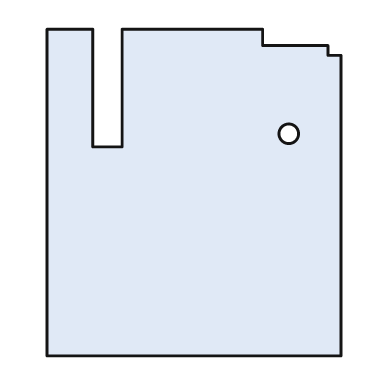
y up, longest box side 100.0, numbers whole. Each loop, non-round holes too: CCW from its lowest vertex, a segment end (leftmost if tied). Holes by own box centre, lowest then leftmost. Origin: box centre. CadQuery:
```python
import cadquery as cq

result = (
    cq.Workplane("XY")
    .moveTo(-45.0, -50.0)
    .lineTo(45.0, -50.0)
    .lineTo(45.0, 42.0)
    .lineTo(41.0, 42.0)
    .lineTo(41.0, 45.0)
    .lineTo(21.0, 45.0)
    .lineTo(21.0, 50.0)
    .lineTo(-22.0, 50.0)
    .lineTo(-22.0, 14.0)
    .lineTo(-31.0, 14.0)
    .lineTo(-31.0, 50.0)
    .lineTo(-45.0, 50.0)
    .close()
    .moveTo(29.0, 18.0)
    .circle(3.0)
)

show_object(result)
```